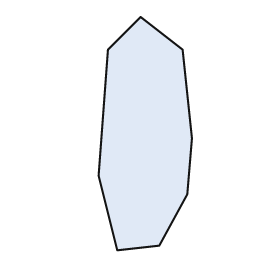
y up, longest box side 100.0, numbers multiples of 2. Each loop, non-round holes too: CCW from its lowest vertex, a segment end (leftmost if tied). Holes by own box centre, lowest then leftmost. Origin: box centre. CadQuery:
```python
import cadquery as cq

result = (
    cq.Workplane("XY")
    .moveTo(-12.0, -50.0)
    .lineTo(6.0, -48.0)
    .lineTo(18.0, -26.0)
    .lineTo(20.0, -2.0)
    .lineTo(16.0, 36.0)
    .lineTo(-2.0, 50.0)
    .lineTo(-16.0, 36.0)
    .lineTo(-20.0, -18.0)
    .close()
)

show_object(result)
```